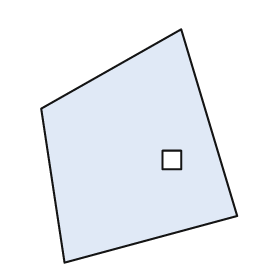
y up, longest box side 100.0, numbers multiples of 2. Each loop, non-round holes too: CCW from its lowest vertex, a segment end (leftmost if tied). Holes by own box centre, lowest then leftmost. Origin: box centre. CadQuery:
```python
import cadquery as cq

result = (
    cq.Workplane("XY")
    .moveTo(-32.0, -50.0)
    .lineTo(42.0, -30.0)
    .lineTo(18.0, 50.0)
    .lineTo(-42.0, 16.0)
    .close()
    .moveTo(10.0, -10.0)
    .lineTo(18.0, -10.0)
    .lineTo(18.0, -2.0)
    .lineTo(10.0, -2.0)
    .close()
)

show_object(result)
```